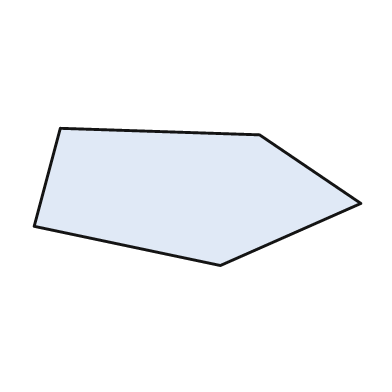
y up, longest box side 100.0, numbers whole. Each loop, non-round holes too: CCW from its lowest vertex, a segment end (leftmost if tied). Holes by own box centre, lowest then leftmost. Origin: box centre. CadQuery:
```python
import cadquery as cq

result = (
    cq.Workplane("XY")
    .moveTo(7.0, -21.0)
    .lineTo(50.0, -2.0)
    .lineTo(19.0, 19.0)
    .lineTo(-42.0, 21.0)
    .lineTo(-50.0, -9.0)
    .close()
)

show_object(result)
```